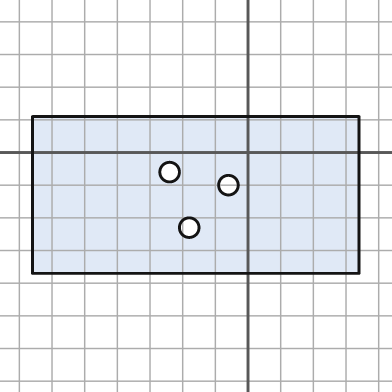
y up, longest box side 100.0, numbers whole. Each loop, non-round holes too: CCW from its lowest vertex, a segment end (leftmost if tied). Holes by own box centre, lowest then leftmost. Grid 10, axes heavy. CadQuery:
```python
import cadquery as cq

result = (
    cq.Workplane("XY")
    .moveTo(-66.0, -37.0)
    .lineTo(34.0, -37.0)
    .lineTo(34.0, 11.0)
    .lineTo(-66.0, 11.0)
    .close()
    .moveTo(-18.0, -23.0)
    .circle(3.0)
    .moveTo(-6.0, -10.0)
    .circle(3.0)
    .moveTo(-24.0, -6.0)
    .circle(3.0)
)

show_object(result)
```